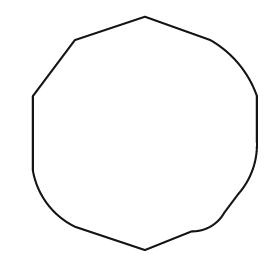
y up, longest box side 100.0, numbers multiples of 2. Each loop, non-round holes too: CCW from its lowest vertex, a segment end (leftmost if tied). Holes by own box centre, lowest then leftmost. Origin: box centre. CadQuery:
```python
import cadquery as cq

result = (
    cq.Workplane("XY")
    .moveTo(0.0, -50.0)
    .lineTo(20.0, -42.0)
    .threePointArc((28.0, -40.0), (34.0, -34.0))
    .lineTo(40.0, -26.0)
    .threePointArc((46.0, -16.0), (48.0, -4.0))
    .lineTo(48.0, 16.0)
    .threePointArc((40.0, 30.0), (28.0, 40.0))
    .lineTo(0.0, 50.0)
    .lineTo(-30.0, 40.0)
    .lineTo(-48.0, 16.0)
    .lineTo(-48.0, -16.0)
    .threePointArc((-42.0, -30.0), (-30.0, -40.0))
    .close()
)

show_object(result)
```